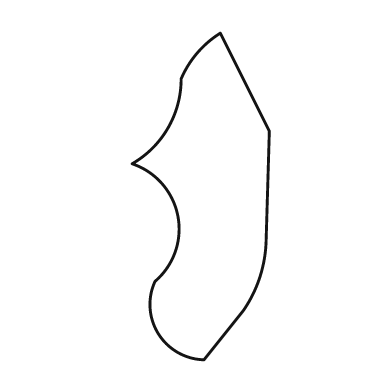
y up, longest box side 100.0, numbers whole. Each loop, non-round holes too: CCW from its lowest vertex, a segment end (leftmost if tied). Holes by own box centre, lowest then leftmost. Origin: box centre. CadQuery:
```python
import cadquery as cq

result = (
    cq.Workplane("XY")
    .moveTo(1.0, -50.0)
    .lineTo(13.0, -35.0)
    .threePointArc((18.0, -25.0), (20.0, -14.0))
    .lineTo(21.0, 20.0)
    .lineTo(6.0, 50.0)
    .threePointArc((-1.0, 44.0), (-6.0, 36.0))
    .threePointArc((-10.0, 21.0), (-21.0, 10.0))
    .threePointArc((-7.0, -6.0), (-14.0, -26.0))
    .threePointArc((-13.0, -42.0), (1.0, -50.0))
    .close()
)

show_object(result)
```